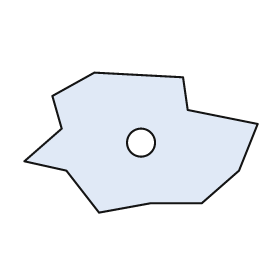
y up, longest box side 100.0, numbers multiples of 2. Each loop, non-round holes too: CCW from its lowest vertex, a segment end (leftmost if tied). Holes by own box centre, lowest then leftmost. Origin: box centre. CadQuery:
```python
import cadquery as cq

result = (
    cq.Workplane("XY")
    .moveTo(-18.0, -30.0)
    .lineTo(4.0, -26.0)
    .lineTo(26.0, -26.0)
    .lineTo(42.0, -12.0)
    .lineTo(50.0, 8.0)
    .lineTo(20.0, 14.0)
    .lineTo(18.0, 28.0)
    .lineTo(-20.0, 30.0)
    .lineTo(-38.0, 20.0)
    .lineTo(-34.0, 6.0)
    .lineTo(-50.0, -8.0)
    .lineTo(-32.0, -12.0)
    .close()
    .moveTo(0.0, 0.0)
    .circle(6.0)
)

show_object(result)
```